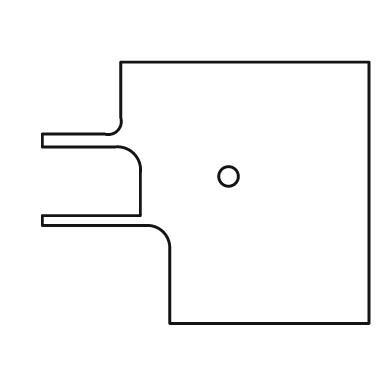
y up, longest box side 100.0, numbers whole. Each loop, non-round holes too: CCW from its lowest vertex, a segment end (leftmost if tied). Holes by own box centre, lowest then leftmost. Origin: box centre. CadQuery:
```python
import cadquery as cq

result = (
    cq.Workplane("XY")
    .moveTo(-11.0, -40.0)
    .lineTo(50.0, -40.0)
    .lineTo(50.0, 40.0)
    .lineTo(-26.0, 40.0)
    .lineTo(-26.0, 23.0)
    .threePointArc((-27.0, 19.0), (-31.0, 18.0))
    .lineTo(-50.0, 18.0)
    .lineTo(-50.0, 14.0)
    .lineTo(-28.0, 14.0)
    .threePointArc((-22.0, 12.0), (-20.0, 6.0))
    .lineTo(-20.0, -7.0)
    .lineTo(-50.0, -7.0)
    .lineTo(-50.0, -10.0)
    .lineTo(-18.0, -10.0)
    .threePointArc((-13.0, -12.0), (-11.0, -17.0))
    .close()
    .moveTo(7.0, 5.0)
    .circle(3.0)
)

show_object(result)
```